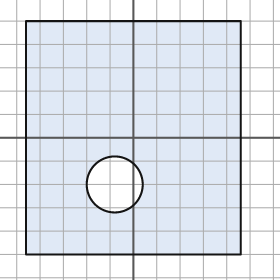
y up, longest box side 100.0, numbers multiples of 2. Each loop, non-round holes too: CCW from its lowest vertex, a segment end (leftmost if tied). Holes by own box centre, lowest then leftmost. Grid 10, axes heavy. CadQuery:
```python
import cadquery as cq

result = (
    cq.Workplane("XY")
    .moveTo(-46.0, -50.0)
    .lineTo(46.0, -50.0)
    .lineTo(46.0, 50.0)
    .lineTo(-46.0, 50.0)
    .close()
    .moveTo(-8.0, -20.0)
    .circle(12.0)
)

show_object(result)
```